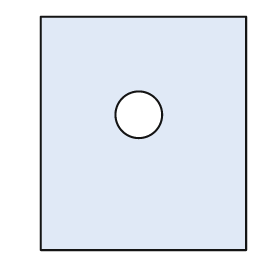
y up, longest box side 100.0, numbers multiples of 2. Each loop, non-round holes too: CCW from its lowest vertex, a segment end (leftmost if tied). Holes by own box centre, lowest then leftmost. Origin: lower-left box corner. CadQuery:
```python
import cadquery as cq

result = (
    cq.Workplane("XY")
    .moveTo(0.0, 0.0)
    .lineTo(88.0, 0.0)
    .lineTo(88.0, 100.0)
    .lineTo(0.0, 100.0)
    .close()
    .moveTo(42.0, 58.0)
    .circle(10.0)
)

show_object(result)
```